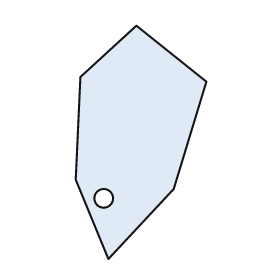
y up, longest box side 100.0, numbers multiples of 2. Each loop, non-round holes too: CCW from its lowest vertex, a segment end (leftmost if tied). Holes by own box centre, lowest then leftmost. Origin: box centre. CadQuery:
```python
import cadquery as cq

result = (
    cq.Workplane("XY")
    .moveTo(-14.0, -50.0)
    .lineTo(14.0, -20.0)
    .lineTo(28.0, 26.0)
    .lineTo(-2.0, 50.0)
    .lineTo(-26.0, 28.0)
    .lineTo(-28.0, -16.0)
    .close()
    .moveTo(-16.0, -24.0)
    .circle(4.0)
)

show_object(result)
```